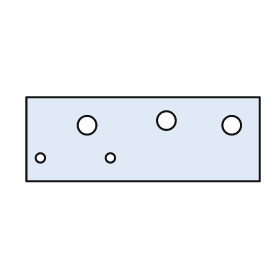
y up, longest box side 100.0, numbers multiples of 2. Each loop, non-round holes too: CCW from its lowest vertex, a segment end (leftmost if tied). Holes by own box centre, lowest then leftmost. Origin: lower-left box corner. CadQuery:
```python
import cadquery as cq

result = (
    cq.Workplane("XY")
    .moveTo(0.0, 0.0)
    .lineTo(100.0, 0.0)
    .lineTo(100.0, 36.0)
    .lineTo(0.0, 36.0)
    .close()
    .moveTo(6.0, 10.0)
    .circle(2.0)
    .moveTo(36.0, 10.0)
    .circle(2.0)
    .moveTo(26.0, 24.0)
    .circle(4.0)
    .moveTo(88.0, 24.0)
    .circle(4.0)
    .moveTo(60.0, 26.0)
    .circle(4.0)
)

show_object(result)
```